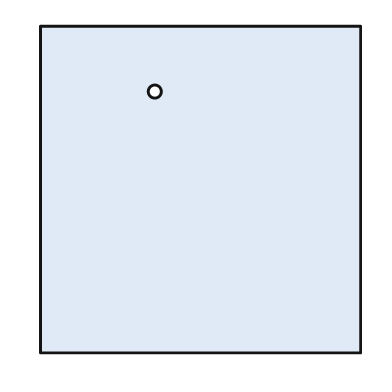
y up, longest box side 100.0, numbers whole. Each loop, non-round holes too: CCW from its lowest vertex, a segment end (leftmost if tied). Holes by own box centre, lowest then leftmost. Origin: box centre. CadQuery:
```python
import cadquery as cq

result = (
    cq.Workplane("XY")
    .moveTo(-49.0, -50.0)
    .lineTo(49.0, -50.0)
    .lineTo(49.0, 50.0)
    .lineTo(-49.0, 50.0)
    .close()
    .moveTo(-14.0, 30.0)
    .circle(2.0)
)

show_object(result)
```